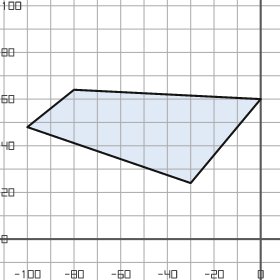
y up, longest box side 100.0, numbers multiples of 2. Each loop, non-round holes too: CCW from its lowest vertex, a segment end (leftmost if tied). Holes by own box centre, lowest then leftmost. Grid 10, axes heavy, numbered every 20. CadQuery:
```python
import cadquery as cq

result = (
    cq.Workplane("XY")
    .moveTo(-30.0, 24.0)
    .lineTo(0.0, 60.0)
    .lineTo(-80.0, 64.0)
    .lineTo(-100.0, 48.0)
    .close()
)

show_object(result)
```